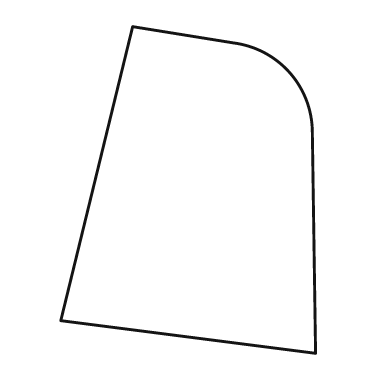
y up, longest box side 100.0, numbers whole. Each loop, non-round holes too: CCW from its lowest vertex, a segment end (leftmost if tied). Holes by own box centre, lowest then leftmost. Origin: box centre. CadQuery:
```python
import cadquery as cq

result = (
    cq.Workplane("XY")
    .moveTo(39.0, -50.0)
    .lineTo(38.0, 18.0)
    .threePointArc((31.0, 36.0), (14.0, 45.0))
    .lineTo(-17.0, 50.0)
    .lineTo(-39.0, -40.0)
    .close()
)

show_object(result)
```